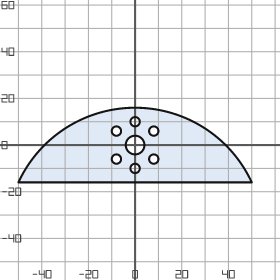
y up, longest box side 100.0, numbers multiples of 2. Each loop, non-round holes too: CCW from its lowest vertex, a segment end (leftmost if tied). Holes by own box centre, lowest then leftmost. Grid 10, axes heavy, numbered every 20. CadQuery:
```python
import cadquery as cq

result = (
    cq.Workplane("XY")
    .moveTo(-50.0, -16.0)
    .lineTo(50.0, -16.0)
    .threePointArc((0.0, 16.0), (-50.0, -16.0))
    .close()
    .moveTo(0.0, -10.0)
    .circle(2.0)
    .moveTo(-8.0, -6.0)
    .circle(2.0)
    .moveTo(8.0, -6.0)
    .circle(2.0)
    .moveTo(0.0, 0.0)
    .circle(4.0)
    .moveTo(-8.0, 6.0)
    .circle(2.0)
    .moveTo(8.0, 6.0)
    .circle(2.0)
    .moveTo(0.0, 10.0)
    .circle(2.0)
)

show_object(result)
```